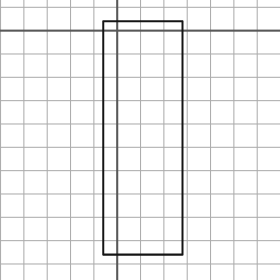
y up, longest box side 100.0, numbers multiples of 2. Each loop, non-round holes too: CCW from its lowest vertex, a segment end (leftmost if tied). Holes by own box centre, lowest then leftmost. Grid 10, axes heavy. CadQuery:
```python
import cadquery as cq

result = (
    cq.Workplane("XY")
    .moveTo(-6.0, -96.0)
    .lineTo(28.0, -96.0)
    .lineTo(28.0, 4.0)
    .lineTo(-6.0, 4.0)
    .close()
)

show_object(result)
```